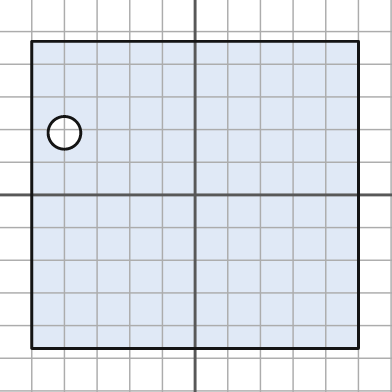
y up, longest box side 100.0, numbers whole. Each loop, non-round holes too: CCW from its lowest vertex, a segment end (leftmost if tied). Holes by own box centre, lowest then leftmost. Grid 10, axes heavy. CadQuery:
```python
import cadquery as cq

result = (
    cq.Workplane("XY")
    .moveTo(-50.0, -47.0)
    .lineTo(50.0, -47.0)
    .lineTo(50.0, 47.0)
    .lineTo(-50.0, 47.0)
    .close()
    .moveTo(-40.0, 19.0)
    .circle(5.0)
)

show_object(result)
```